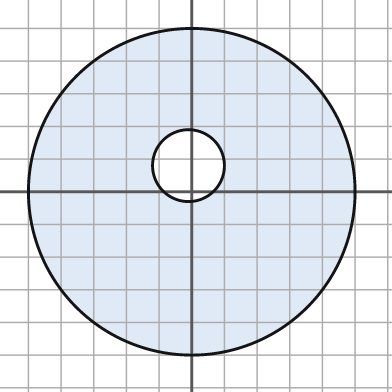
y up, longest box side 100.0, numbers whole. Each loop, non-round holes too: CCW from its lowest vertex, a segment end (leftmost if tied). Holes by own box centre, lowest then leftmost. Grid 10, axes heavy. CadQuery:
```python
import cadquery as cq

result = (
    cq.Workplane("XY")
    .moveTo(0.0, 0.0)
    .circle(50.0)
    .moveTo(-1.0, 8.0)
    .circle(11.0)
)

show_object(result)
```